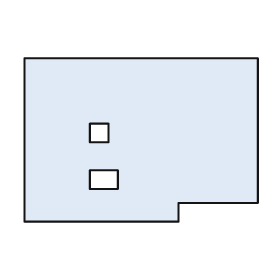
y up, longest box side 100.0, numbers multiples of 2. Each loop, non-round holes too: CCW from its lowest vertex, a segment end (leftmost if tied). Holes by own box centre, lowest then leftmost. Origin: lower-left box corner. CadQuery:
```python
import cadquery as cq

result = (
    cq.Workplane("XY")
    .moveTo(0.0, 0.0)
    .lineTo(66.0, 0.0)
    .lineTo(66.0, 8.0)
    .lineTo(100.0, 8.0)
    .lineTo(100.0, 70.0)
    .lineTo(0.0, 70.0)
    .close()
    .moveTo(28.0, 14.0)
    .lineTo(40.0, 14.0)
    .lineTo(40.0, 22.0)
    .lineTo(28.0, 22.0)
    .close()
    .moveTo(28.0, 34.0)
    .lineTo(36.0, 34.0)
    .lineTo(36.0, 42.0)
    .lineTo(28.0, 42.0)
    .close()
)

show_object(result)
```